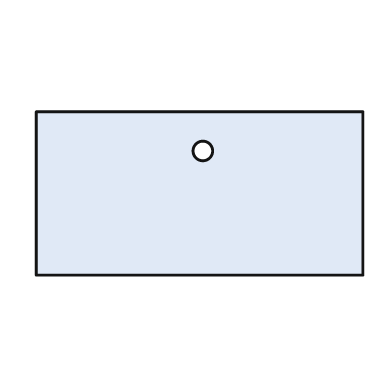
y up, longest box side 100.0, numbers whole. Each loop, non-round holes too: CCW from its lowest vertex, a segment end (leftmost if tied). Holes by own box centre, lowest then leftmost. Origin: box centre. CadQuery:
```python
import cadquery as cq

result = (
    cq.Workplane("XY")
    .moveTo(-50.0, -25.0)
    .lineTo(50.0, -25.0)
    .lineTo(50.0, 25.0)
    .lineTo(-50.0, 25.0)
    .close()
    .moveTo(1.0, 13.0)
    .circle(3.0)
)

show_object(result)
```